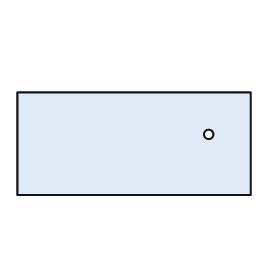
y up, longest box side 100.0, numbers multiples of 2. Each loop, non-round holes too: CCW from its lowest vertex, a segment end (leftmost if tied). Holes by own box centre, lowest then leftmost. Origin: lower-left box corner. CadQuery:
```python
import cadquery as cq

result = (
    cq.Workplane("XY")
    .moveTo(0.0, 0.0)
    .lineTo(100.0, 0.0)
    .lineTo(100.0, 44.0)
    .lineTo(0.0, 44.0)
    .close()
    .moveTo(82.0, 26.0)
    .circle(2.0)
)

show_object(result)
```